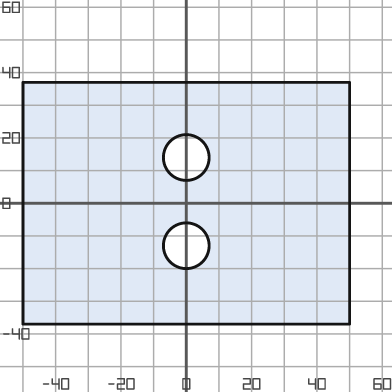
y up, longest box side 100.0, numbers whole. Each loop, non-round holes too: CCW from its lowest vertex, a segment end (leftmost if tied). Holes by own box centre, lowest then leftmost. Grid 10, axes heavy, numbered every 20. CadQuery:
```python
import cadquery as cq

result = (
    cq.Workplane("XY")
    .moveTo(-50.0, -37.0)
    .lineTo(50.0, -37.0)
    .lineTo(50.0, 37.0)
    .lineTo(-50.0, 37.0)
    .close()
    .moveTo(0.0, -13.0)
    .circle(7.0)
    .moveTo(0.0, 14.0)
    .circle(7.0)
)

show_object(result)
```